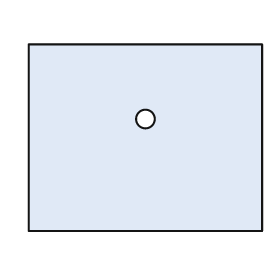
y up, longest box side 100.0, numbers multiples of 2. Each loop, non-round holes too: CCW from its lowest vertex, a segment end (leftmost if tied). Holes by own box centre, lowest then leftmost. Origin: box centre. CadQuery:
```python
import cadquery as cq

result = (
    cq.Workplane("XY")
    .moveTo(-50.0, -40.0)
    .lineTo(50.0, -40.0)
    .lineTo(50.0, 40.0)
    .lineTo(-50.0, 40.0)
    .close()
    .moveTo(0.0, 8.0)
    .circle(4.0)
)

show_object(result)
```